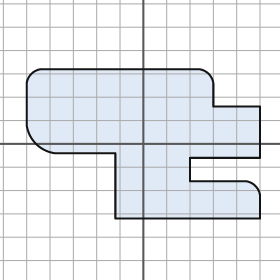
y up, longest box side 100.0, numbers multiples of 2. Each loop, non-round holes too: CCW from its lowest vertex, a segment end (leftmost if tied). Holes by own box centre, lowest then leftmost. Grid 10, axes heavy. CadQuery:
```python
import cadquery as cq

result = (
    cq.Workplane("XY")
    .moveTo(-12.0, -32.0)
    .lineTo(50.0, -32.0)
    .lineTo(50.0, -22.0)
    .threePointArc((48.0, -18.0), (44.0, -16.0))
    .lineTo(20.0, -16.0)
    .lineTo(20.0, -6.0)
    .lineTo(50.0, -6.0)
    .lineTo(50.0, 16.0)
    .lineTo(30.0, 16.0)
    .lineTo(30.0, 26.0)
    .threePointArc((28.0, 30.0), (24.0, 32.0))
    .lineTo(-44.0, 32.0)
    .threePointArc((-48.0, 30.0), (-50.0, 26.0))
    .lineTo(-50.0, 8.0)
    .threePointArc((-46.0, 0.0), (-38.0, -4.0))
    .lineTo(-12.0, -4.0)
    .close()
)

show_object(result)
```